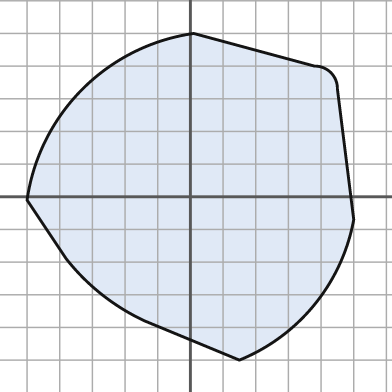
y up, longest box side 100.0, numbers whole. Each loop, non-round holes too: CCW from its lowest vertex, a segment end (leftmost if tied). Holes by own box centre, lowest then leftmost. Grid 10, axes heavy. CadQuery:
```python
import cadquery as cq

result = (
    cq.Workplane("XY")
    .moveTo(15.0, -50.0)
    .threePointArc((38.0, -33.0), (50.0, -7.0))
    .lineTo(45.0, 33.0)
    .threePointArc((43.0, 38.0), (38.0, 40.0))
    .lineTo(1.0, 50.0)
    .threePointArc((-33.0, 33.0), (-50.0, -1.0))
    .lineTo(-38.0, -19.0)
    .threePointArc((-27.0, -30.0), (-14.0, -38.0))
    .close()
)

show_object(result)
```